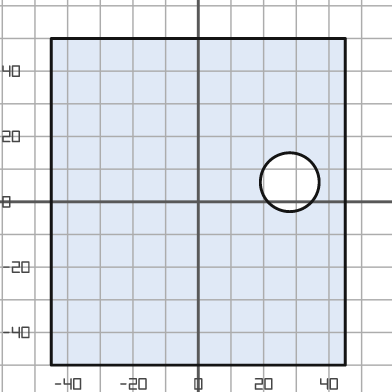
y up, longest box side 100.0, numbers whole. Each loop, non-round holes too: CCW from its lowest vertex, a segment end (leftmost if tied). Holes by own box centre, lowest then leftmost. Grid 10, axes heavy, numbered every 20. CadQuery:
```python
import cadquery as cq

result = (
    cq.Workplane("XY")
    .moveTo(-45.0, -50.0)
    .lineTo(45.0, -50.0)
    .lineTo(45.0, 50.0)
    .lineTo(-45.0, 50.0)
    .close()
    .moveTo(28.0, 6.0)
    .circle(9.0)
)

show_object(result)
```